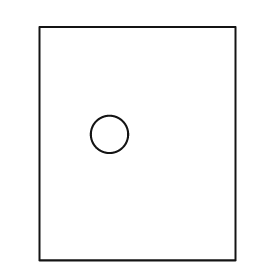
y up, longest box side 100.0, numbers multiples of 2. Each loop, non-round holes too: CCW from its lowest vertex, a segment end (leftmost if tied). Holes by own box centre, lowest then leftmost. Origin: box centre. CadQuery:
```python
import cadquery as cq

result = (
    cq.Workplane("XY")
    .moveTo(-42.0, -50.0)
    .lineTo(42.0, -50.0)
    .lineTo(42.0, 50.0)
    .lineTo(-42.0, 50.0)
    .close()
    .moveTo(-12.0, 4.0)
    .circle(8.0)
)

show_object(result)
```